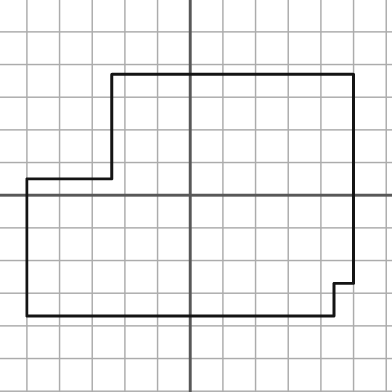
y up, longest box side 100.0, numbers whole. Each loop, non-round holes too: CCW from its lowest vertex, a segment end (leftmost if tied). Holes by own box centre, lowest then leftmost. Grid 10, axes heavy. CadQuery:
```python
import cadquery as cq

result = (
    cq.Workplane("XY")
    .moveTo(-50.0, -37.0)
    .lineTo(44.0, -37.0)
    .lineTo(44.0, -27.0)
    .lineTo(50.0, -27.0)
    .lineTo(50.0, 37.0)
    .lineTo(-24.0, 37.0)
    .lineTo(-24.0, 5.0)
    .lineTo(-50.0, 5.0)
    .close()
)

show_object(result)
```